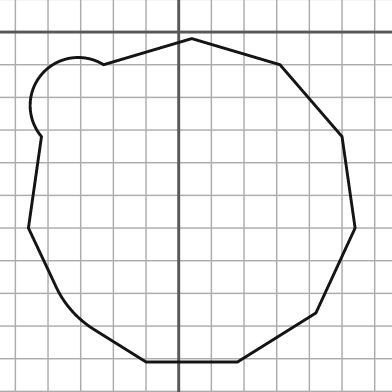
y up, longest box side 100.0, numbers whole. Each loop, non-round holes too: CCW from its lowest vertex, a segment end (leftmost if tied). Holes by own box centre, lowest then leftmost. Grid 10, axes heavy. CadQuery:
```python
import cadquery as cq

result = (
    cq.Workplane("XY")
    .moveTo(-10.0, -101.0)
    .lineTo(18.0, -101.0)
    .lineTo(42.0, -86.0)
    .lineTo(54.0, -60.0)
    .lineTo(50.0, -32.0)
    .lineTo(31.0, -10.0)
    .lineTo(4.0, -2.0)
    .lineTo(-23.0, -10.0)
    .threePointArc((-42.0, -13.0), (-42.0, -32.0))
    .lineTo(-46.0, -60.0)
    .lineTo(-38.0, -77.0)
    .threePointArc((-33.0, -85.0), (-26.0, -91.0))
    .close()
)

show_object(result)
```